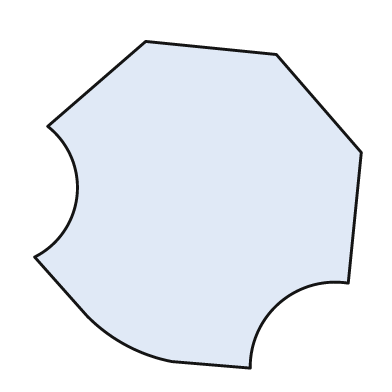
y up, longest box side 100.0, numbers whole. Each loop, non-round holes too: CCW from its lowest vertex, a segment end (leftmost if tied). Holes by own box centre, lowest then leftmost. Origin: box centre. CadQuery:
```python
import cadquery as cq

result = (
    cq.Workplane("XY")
    .moveTo(16.0, -50.0)
    .threePointArc((25.0, -30.0), (46.0, -24.0))
    .lineTo(50.0, 16.0)
    .lineTo(24.0, 46.0)
    .lineTo(-16.0, 50.0)
    .lineTo(-46.0, 24.0)
    .threePointArc((-37.0, 3.0), (-50.0, -16.0))
    .lineTo(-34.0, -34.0)
    .threePointArc((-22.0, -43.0), (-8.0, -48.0))
    .close()
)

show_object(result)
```